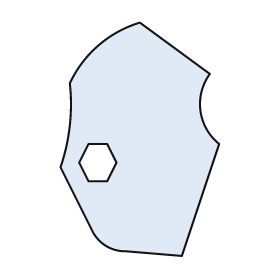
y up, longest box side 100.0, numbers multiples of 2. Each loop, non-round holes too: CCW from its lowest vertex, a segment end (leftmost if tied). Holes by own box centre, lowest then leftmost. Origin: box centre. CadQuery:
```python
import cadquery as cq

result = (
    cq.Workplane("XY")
    .moveTo(18.0, -50.0)
    .lineTo(34.0, -2.0)
    .threePointArc((26.0, 12.0), (30.0, 28.0))
    .lineTo(0.0, 50.0)
    .threePointArc((-18.0, 40.0), (-30.0, 24.0))
    .threePointArc((-30.0, 6.0), (-34.0, -12.0))
    .lineTo(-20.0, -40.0)
    .threePointArc((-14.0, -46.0), (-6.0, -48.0))
    .close()
    .moveTo(-22.0, -18.0)
    .lineTo(-14.0, -18.0)
    .lineTo(-10.0, -10.0)
    .lineTo(-14.0, -2.0)
    .lineTo(-22.0, -2.0)
    .lineTo(-26.0, -10.0)
    .close()
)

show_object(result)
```